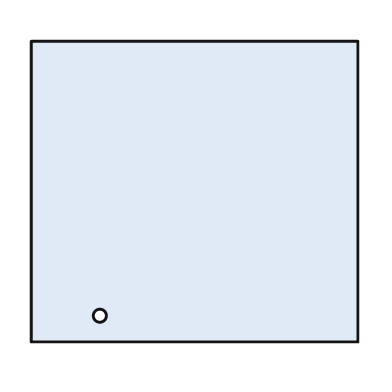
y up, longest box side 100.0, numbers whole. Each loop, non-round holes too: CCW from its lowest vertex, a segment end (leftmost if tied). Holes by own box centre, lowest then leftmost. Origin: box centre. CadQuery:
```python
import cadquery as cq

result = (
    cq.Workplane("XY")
    .moveTo(-50.0, -46.0)
    .lineTo(50.0, -46.0)
    .lineTo(50.0, 46.0)
    .lineTo(-50.0, 46.0)
    .close()
    .moveTo(-29.0, -38.0)
    .circle(2.0)
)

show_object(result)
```